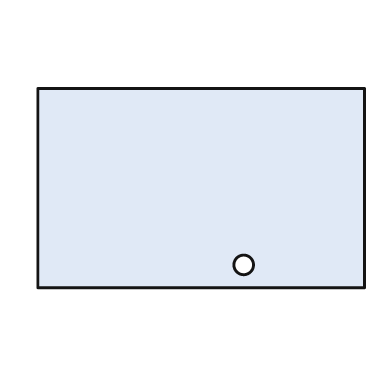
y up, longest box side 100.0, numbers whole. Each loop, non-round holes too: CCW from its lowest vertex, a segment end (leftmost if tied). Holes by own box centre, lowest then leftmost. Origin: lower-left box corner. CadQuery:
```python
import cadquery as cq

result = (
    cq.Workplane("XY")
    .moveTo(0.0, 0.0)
    .lineTo(100.0, 0.0)
    .lineTo(100.0, 61.0)
    .lineTo(0.0, 61.0)
    .close()
    .moveTo(63.0, 7.0)
    .circle(3.0)
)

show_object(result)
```